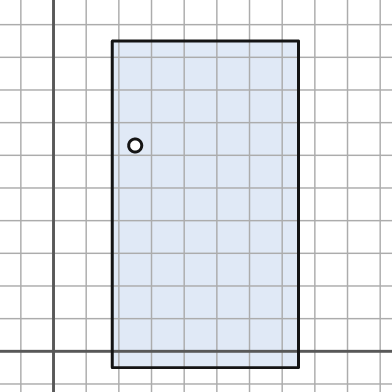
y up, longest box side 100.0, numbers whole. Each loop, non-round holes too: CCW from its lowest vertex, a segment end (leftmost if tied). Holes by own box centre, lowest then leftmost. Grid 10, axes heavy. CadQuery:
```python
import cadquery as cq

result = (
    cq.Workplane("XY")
    .moveTo(18.0, -5.0)
    .lineTo(75.0, -5.0)
    .lineTo(75.0, 95.0)
    .lineTo(18.0, 95.0)
    .close()
    .moveTo(25.0, 63.0)
    .circle(2.0)
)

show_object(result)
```